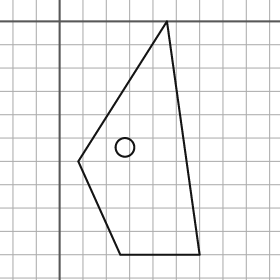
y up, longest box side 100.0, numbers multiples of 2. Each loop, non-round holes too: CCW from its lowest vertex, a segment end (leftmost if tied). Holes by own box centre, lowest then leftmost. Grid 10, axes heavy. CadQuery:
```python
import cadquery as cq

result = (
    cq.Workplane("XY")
    .moveTo(26.0, -100.0)
    .lineTo(60.0, -100.0)
    .lineTo(46.0, 0.0)
    .lineTo(8.0, -60.0)
    .close()
    .moveTo(28.0, -54.0)
    .circle(4.0)
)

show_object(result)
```